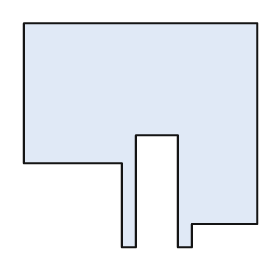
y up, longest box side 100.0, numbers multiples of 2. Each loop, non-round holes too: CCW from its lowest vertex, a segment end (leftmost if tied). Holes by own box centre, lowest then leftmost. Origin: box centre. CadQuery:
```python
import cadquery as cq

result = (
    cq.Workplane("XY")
    .moveTo(-8.0, -48.0)
    .lineTo(-2.0, -48.0)
    .lineTo(-2.0, 0.0)
    .lineTo(16.0, 0.0)
    .lineTo(16.0, -48.0)
    .lineTo(22.0, -48.0)
    .lineTo(22.0, -38.0)
    .lineTo(50.0, -38.0)
    .lineTo(50.0, 48.0)
    .lineTo(-50.0, 48.0)
    .lineTo(-50.0, -12.0)
    .lineTo(-8.0, -12.0)
    .close()
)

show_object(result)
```